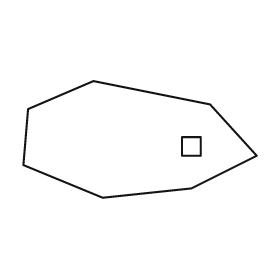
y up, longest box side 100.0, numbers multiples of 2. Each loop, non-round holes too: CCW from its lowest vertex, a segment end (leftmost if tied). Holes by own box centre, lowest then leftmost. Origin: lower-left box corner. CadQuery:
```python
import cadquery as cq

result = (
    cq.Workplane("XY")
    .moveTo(34.0, 0.0)
    .lineTo(72.0, 4.0)
    .lineTo(100.0, 18.0)
    .lineTo(80.0, 40.0)
    .lineTo(30.0, 50.0)
    .lineTo(2.0, 38.0)
    .lineTo(0.0, 14.0)
    .close()
    .moveTo(68.0, 18.0)
    .lineTo(76.0, 18.0)
    .lineTo(76.0, 26.0)
    .lineTo(68.0, 26.0)
    .close()
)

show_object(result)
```